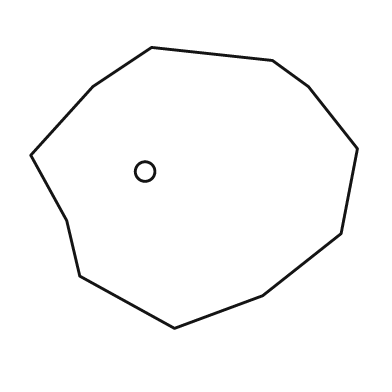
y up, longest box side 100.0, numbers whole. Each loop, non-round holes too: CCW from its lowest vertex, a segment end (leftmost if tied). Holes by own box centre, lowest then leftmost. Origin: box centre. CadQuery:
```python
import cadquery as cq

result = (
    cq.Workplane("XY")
    .moveTo(-6.0, -43.0)
    .lineTo(21.0, -33.0)
    .lineTo(45.0, -14.0)
    .lineTo(50.0, 12.0)
    .lineTo(35.0, 31.0)
    .lineTo(24.0, 39.0)
    .lineTo(-13.0, 43.0)
    .lineTo(-31.0, 31.0)
    .lineTo(-50.0, 10.0)
    .lineTo(-39.0, -10.0)
    .lineTo(-35.0, -27.0)
    .close()
    .moveTo(-15.0, 5.0)
    .circle(3.0)
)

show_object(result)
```